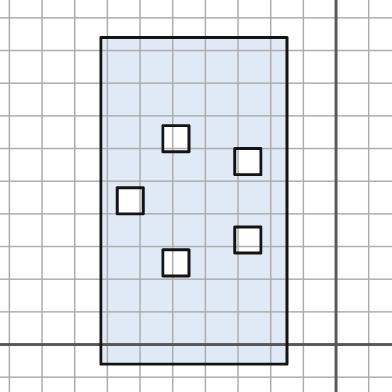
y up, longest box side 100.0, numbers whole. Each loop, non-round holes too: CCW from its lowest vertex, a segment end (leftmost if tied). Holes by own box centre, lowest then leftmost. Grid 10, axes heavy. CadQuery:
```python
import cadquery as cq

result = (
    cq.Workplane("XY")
    .moveTo(-72.0, -6.0)
    .lineTo(-15.0, -6.0)
    .lineTo(-15.0, 94.0)
    .lineTo(-72.0, 94.0)
    .close()
    .moveTo(-53.0, 21.0)
    .lineTo(-45.0, 21.0)
    .lineTo(-45.0, 29.0)
    .lineTo(-53.0, 29.0)
    .close()
    .moveTo(-31.0, 28.0)
    .lineTo(-23.0, 28.0)
    .lineTo(-23.0, 36.0)
    .lineTo(-31.0, 36.0)
    .close()
    .moveTo(-67.0, 40.0)
    .lineTo(-59.0, 40.0)
    .lineTo(-59.0, 48.0)
    .lineTo(-67.0, 48.0)
    .close()
    .moveTo(-31.0, 52.0)
    .lineTo(-23.0, 52.0)
    .lineTo(-23.0, 60.0)
    .lineTo(-31.0, 60.0)
    .close()
    .moveTo(-53.0, 59.0)
    .lineTo(-45.0, 59.0)
    .lineTo(-45.0, 67.0)
    .lineTo(-53.0, 67.0)
    .close()
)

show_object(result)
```